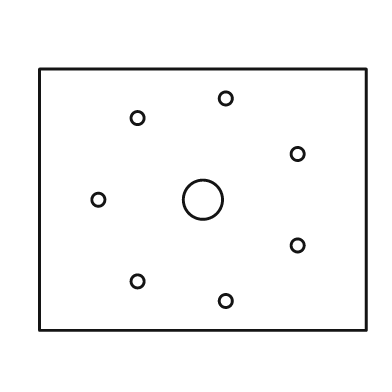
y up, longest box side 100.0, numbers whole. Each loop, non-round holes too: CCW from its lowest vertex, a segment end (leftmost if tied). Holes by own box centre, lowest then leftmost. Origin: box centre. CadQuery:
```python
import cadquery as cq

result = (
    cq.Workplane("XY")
    .moveTo(-50.0, -40.0)
    .lineTo(50.0, -40.0)
    .lineTo(50.0, 40.0)
    .lineTo(-50.0, 40.0)
    .close()
    .moveTo(7.0, -31.0)
    .circle(2.0)
    .moveTo(-20.0, -25.0)
    .circle(2.0)
    .moveTo(29.0, -14.0)
    .circle(2.0)
    .moveTo(-32.0, 0.0)
    .circle(2.0)
    .moveTo(0.0, 0.0)
    .circle(6.0)
    .moveTo(29.0, 14.0)
    .circle(2.0)
    .moveTo(-20.0, 25.0)
    .circle(2.0)
    .moveTo(7.0, 31.0)
    .circle(2.0)
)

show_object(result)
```